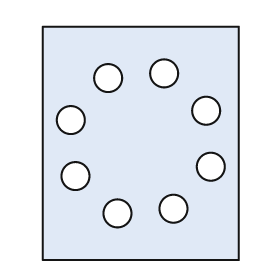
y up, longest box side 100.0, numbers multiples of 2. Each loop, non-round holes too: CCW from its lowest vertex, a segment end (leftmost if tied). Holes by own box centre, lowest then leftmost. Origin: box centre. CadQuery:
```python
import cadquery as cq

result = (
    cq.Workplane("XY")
    .moveTo(-42.0, -50.0)
    .lineTo(42.0, -50.0)
    .lineTo(42.0, 50.0)
    .lineTo(-42.0, 50.0)
    .close()
    .moveTo(-10.0, -30.0)
    .circle(6.0)
    .moveTo(14.0, -28.0)
    .circle(6.0)
    .moveTo(-28.0, -14.0)
    .circle(6.0)
    .moveTo(30.0, -10.0)
    .circle(6.0)
    .moveTo(-30.0, 10.0)
    .circle(6.0)
    .moveTo(28.0, 14.0)
    .circle(6.0)
    .moveTo(-14.0, 28.0)
    .circle(6.0)
    .moveTo(10.0, 30.0)
    .circle(6.0)
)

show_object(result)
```